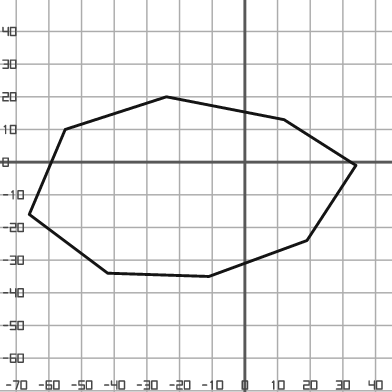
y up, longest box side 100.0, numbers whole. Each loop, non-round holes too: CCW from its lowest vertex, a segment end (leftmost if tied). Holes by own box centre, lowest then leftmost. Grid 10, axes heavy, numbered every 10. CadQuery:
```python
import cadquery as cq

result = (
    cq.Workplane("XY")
    .moveTo(-11.0, -35.0)
    .lineTo(19.0, -24.0)
    .lineTo(34.0, -1.0)
    .lineTo(12.0, 13.0)
    .lineTo(-24.0, 20.0)
    .lineTo(-55.0, 10.0)
    .lineTo(-66.0, -16.0)
    .lineTo(-42.0, -34.0)
    .close()
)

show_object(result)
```